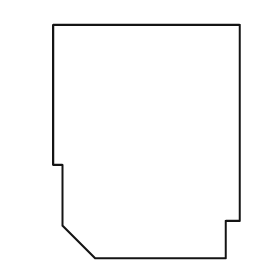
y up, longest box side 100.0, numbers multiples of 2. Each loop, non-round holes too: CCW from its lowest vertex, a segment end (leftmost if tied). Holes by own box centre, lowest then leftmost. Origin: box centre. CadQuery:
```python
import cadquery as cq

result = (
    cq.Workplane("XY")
    .moveTo(-22.0, -50.0)
    .lineTo(34.0, -50.0)
    .lineTo(34.0, -34.0)
    .lineTo(40.0, -34.0)
    .lineTo(40.0, 50.0)
    .lineTo(-40.0, 50.0)
    .lineTo(-40.0, -10.0)
    .lineTo(-36.0, -10.0)
    .lineTo(-36.0, -36.0)
    .close()
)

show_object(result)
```